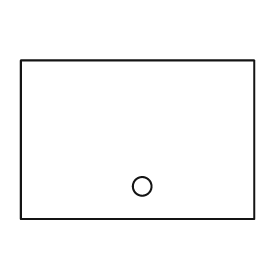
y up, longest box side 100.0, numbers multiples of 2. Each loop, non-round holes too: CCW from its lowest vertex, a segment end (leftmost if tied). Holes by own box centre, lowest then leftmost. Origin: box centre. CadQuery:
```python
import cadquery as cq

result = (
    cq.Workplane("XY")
    .moveTo(-50.0, -34.0)
    .lineTo(50.0, -34.0)
    .lineTo(50.0, 34.0)
    .lineTo(-50.0, 34.0)
    .close()
    .moveTo(2.0, -20.0)
    .circle(4.0)
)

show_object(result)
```